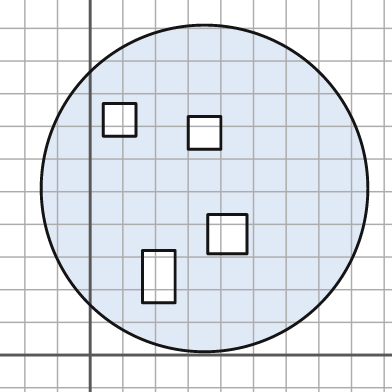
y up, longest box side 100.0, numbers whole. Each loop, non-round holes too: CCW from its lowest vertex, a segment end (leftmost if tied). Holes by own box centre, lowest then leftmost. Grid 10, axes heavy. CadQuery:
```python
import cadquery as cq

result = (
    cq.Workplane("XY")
    .moveTo(35.0, 51.0)
    .circle(50.0)
    .moveTo(16.0, 16.0)
    .lineTo(26.0, 16.0)
    .lineTo(26.0, 32.0)
    .lineTo(16.0, 32.0)
    .close()
    .moveTo(36.0, 31.0)
    .lineTo(48.0, 31.0)
    .lineTo(48.0, 43.0)
    .lineTo(36.0, 43.0)
    .close()
    .moveTo(30.0, 63.0)
    .lineTo(40.0, 63.0)
    .lineTo(40.0, 73.0)
    .lineTo(30.0, 73.0)
    .close()
    .moveTo(4.0, 67.0)
    .lineTo(14.0, 67.0)
    .lineTo(14.0, 77.0)
    .lineTo(4.0, 77.0)
    .close()
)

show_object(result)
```